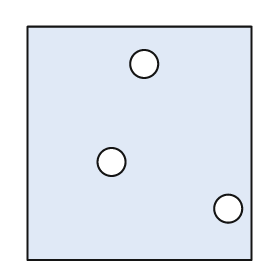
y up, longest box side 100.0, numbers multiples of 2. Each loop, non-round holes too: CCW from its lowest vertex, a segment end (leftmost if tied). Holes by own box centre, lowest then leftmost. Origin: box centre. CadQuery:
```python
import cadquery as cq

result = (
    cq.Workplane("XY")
    .moveTo(-48.0, -50.0)
    .lineTo(48.0, -50.0)
    .lineTo(48.0, 50.0)
    .lineTo(-48.0, 50.0)
    .close()
    .moveTo(38.0, -28.0)
    .circle(6.0)
    .moveTo(-12.0, -8.0)
    .circle(6.0)
    .moveTo(2.0, 34.0)
    .circle(6.0)
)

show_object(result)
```